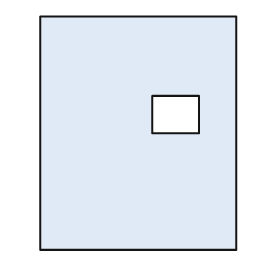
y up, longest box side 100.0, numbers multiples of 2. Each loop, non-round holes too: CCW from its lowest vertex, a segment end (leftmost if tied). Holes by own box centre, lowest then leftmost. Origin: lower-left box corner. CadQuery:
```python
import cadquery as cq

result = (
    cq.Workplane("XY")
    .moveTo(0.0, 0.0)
    .lineTo(84.0, 0.0)
    .lineTo(84.0, 100.0)
    .lineTo(0.0, 100.0)
    .close()
    .moveTo(48.0, 50.0)
    .lineTo(68.0, 50.0)
    .lineTo(68.0, 66.0)
    .lineTo(48.0, 66.0)
    .close()
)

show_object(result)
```